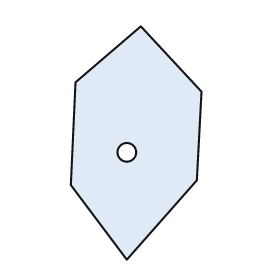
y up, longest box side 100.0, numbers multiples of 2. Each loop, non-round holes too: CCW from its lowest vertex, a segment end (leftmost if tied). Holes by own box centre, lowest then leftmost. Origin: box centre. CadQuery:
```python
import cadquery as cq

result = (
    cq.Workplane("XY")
    .moveTo(-4.0, -50.0)
    .lineTo(26.0, -16.0)
    .lineTo(28.0, 22.0)
    .lineTo(2.0, 50.0)
    .lineTo(-26.0, 26.0)
    .lineTo(-28.0, -18.0)
    .close()
    .moveTo(-4.0, -4.0)
    .circle(4.0)
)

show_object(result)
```